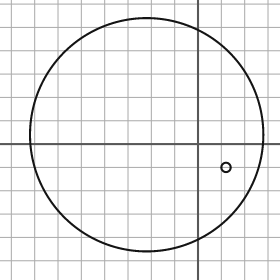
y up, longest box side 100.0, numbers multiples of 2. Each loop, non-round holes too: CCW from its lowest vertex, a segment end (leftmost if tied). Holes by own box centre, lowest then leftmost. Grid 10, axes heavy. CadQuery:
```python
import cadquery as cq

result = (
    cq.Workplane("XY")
    .moveTo(-22.0, 4.0)
    .circle(50.0)
    .moveTo(12.0, -10.0)
    .circle(2.0)
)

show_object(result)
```